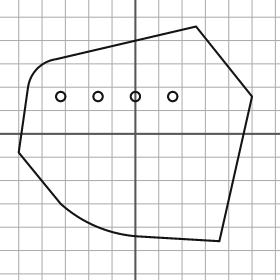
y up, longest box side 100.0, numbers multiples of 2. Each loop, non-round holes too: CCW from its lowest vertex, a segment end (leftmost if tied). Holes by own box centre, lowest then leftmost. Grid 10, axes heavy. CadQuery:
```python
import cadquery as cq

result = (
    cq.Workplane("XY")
    .moveTo(36.0, -46.0)
    .lineTo(50.0, 16.0)
    .lineTo(26.0, 46.0)
    .lineTo(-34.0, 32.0)
    .threePointArc((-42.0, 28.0), (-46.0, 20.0))
    .lineTo(-50.0, -8.0)
    .lineTo(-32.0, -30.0)
    .threePointArc((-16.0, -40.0), (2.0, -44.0))
    .close()
    .moveTo(-32.0, 16.0)
    .circle(2.0)
    .moveTo(-16.0, 16.0)
    .circle(2.0)
    .moveTo(0.0, 16.0)
    .circle(2.0)
    .moveTo(16.0, 16.0)
    .circle(2.0)
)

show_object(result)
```